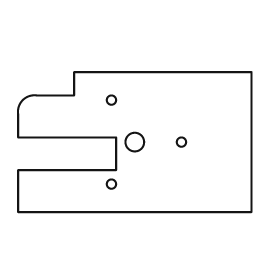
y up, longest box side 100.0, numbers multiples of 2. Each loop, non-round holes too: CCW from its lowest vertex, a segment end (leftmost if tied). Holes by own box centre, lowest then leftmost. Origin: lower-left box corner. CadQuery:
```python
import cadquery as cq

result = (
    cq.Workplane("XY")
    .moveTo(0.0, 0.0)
    .lineTo(100.0, 0.0)
    .lineTo(100.0, 60.0)
    .lineTo(24.0, 60.0)
    .lineTo(24.0, 50.0)
    .lineTo(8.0, 50.0)
    .threePointArc((2.0, 48.0), (0.0, 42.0))
    .lineTo(0.0, 32.0)
    .lineTo(42.0, 32.0)
    .lineTo(42.0, 18.0)
    .lineTo(0.0, 18.0)
    .close()
    .moveTo(40.0, 12.0)
    .circle(2.0)
    .moveTo(50.0, 30.0)
    .circle(4.0)
    .moveTo(70.0, 30.0)
    .circle(2.0)
    .moveTo(40.0, 48.0)
    .circle(2.0)
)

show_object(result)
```